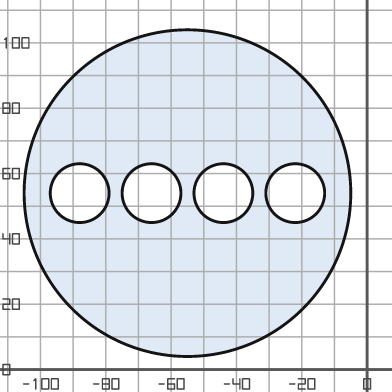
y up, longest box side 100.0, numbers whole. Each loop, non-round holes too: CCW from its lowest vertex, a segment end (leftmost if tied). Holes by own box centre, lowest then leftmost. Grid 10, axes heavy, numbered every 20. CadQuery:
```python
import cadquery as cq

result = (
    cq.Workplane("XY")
    .moveTo(-55.0, 54.0)
    .circle(50.0)
    .moveTo(-88.0, 54.0)
    .circle(9.0)
    .moveTo(-66.0, 54.0)
    .circle(9.0)
    .moveTo(-44.0, 54.0)
    .circle(9.0)
    .moveTo(-22.0, 54.0)
    .circle(9.0)
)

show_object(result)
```